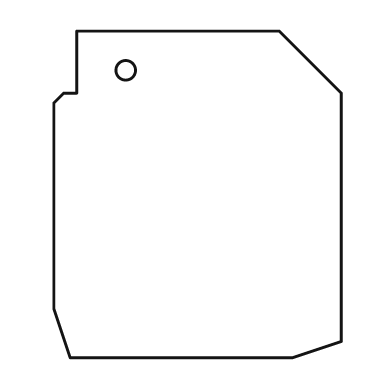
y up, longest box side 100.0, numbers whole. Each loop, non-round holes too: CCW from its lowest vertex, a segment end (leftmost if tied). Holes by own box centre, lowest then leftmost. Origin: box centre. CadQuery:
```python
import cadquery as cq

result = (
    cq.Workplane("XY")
    .moveTo(-39.0, -50.0)
    .lineTo(29.0, -50.0)
    .lineTo(44.0, -45.0)
    .lineTo(44.0, 31.0)
    .lineTo(25.0, 50.0)
    .lineTo(-37.0, 50.0)
    .lineTo(-37.0, 31.0)
    .lineTo(-41.0, 31.0)
    .lineTo(-44.0, 28.0)
    .lineTo(-44.0, -35.0)
    .close()
    .moveTo(-22.0, 38.0)
    .circle(3.0)
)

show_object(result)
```